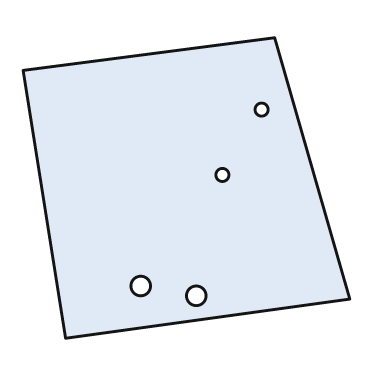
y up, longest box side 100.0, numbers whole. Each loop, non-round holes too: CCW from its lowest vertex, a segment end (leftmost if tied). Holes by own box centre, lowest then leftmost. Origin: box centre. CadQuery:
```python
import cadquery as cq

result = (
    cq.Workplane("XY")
    .moveTo(-37.0, -46.0)
    .lineTo(50.0, -34.0)
    .lineTo(27.0, 46.0)
    .lineTo(-50.0, 36.0)
    .close()
    .moveTo(3.0, -33.0)
    .circle(3.0)
    .moveTo(-14.0, -30.0)
    .circle(3.0)
    .moveTo(11.0, 4.0)
    .circle(2.0)
    .moveTo(23.0, 24.0)
    .circle(2.0)
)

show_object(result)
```